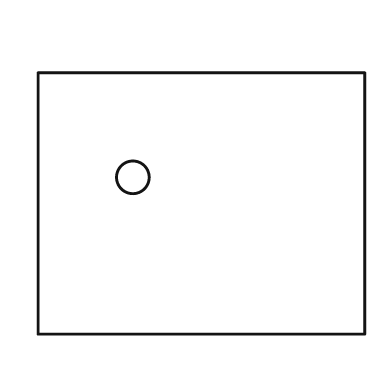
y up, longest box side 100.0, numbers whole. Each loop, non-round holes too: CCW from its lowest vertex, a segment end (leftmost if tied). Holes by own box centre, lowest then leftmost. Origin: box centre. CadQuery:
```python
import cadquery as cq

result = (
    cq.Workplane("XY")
    .moveTo(-50.0, -40.0)
    .lineTo(50.0, -40.0)
    .lineTo(50.0, 40.0)
    .lineTo(-50.0, 40.0)
    .close()
    .moveTo(-21.0, 8.0)
    .circle(5.0)
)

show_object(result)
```